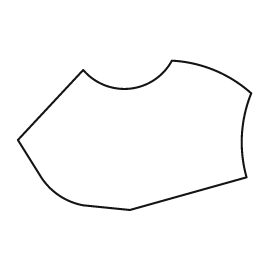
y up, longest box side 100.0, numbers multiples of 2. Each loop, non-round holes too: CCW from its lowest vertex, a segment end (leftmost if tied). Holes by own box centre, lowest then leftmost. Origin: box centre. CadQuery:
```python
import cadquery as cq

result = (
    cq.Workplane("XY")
    .moveTo(-2.0, -32.0)
    .lineTo(48.0, -18.0)
    .threePointArc((46.0, 0.0), (50.0, 18.0))
    .threePointArc((34.0, 28.0), (16.0, 32.0))
    .threePointArc((-2.0, 20.0), (-22.0, 28.0))
    .lineTo(-50.0, -2.0)
    .lineTo(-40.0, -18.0)
    .threePointArc((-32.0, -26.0), (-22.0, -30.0))
    .close()
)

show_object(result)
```